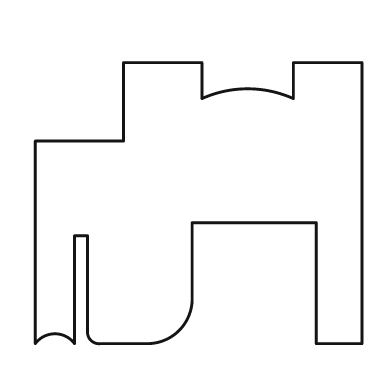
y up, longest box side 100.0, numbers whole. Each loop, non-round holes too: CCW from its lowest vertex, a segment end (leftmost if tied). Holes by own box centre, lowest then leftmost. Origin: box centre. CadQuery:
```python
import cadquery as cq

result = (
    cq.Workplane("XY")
    .moveTo(-50.0, -43.0)
    .threePointArc((-44.0, -40.0), (-38.0, -43.0))
    .lineTo(-38.0, -10.0)
    .lineTo(-34.0, -10.0)
    .lineTo(-34.0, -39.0)
    .threePointArc((-33.0, -42.0), (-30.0, -43.0))
    .lineTo(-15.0, -43.0)
    .threePointArc((-6.0, -39.0), (-2.0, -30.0))
    .lineTo(-2.0, -6.0)
    .lineTo(36.0, -6.0)
    .lineTo(36.0, -43.0)
    .lineTo(50.0, -43.0)
    .lineTo(50.0, 43.0)
    .lineTo(29.0, 43.0)
    .lineTo(29.0, 32.0)
    .threePointArc((15.0, 35.0), (1.0, 32.0))
    .lineTo(1.0, 43.0)
    .lineTo(-23.0, 43.0)
    .lineTo(-23.0, 19.0)
    .lineTo(-50.0, 19.0)
    .close()
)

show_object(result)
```